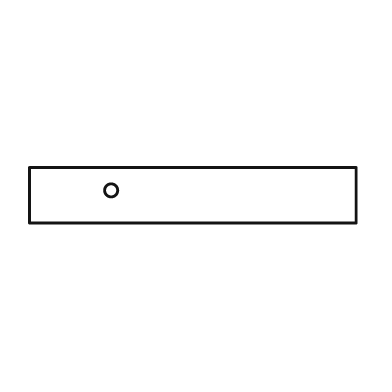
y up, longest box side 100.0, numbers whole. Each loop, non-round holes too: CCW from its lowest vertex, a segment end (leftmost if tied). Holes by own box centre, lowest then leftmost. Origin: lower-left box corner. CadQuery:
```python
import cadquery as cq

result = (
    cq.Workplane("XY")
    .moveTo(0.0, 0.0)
    .lineTo(100.0, 0.0)
    .lineTo(100.0, 17.0)
    .lineTo(0.0, 17.0)
    .close()
    .moveTo(25.0, 10.0)
    .circle(2.0)
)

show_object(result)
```